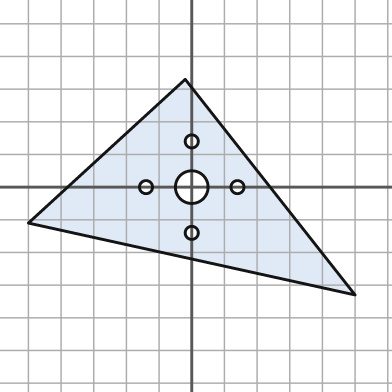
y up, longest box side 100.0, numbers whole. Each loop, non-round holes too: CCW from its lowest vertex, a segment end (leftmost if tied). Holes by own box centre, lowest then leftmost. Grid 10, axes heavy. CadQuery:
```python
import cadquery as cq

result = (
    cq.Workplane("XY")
    .moveTo(50.0, -33.0)
    .lineTo(-2.0, 33.0)
    .lineTo(-50.0, -11.0)
    .close()
    .moveTo(0.0, -14.0)
    .circle(2.0)
    .moveTo(-14.0, 0.0)
    .circle(2.0)
    .moveTo(0.0, 0.0)
    .circle(5.0)
    .moveTo(14.0, 0.0)
    .circle(2.0)
    .moveTo(0.0, 14.0)
    .circle(2.0)
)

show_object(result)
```